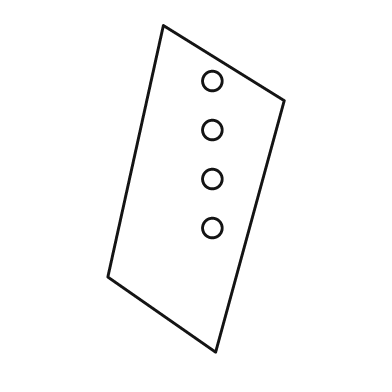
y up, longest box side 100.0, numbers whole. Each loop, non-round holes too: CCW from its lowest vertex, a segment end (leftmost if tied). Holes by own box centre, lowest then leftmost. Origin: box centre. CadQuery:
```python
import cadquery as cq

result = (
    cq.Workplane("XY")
    .moveTo(6.0, -50.0)
    .lineTo(27.0, 27.0)
    .lineTo(-10.0, 50.0)
    .lineTo(-27.0, -27.0)
    .close()
    .moveTo(5.0, -12.0)
    .circle(3.0)
    .moveTo(5.0, 3.0)
    .circle(3.0)
    .moveTo(5.0, 18.0)
    .circle(3.0)
    .moveTo(5.0, 33.0)
    .circle(3.0)
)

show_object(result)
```